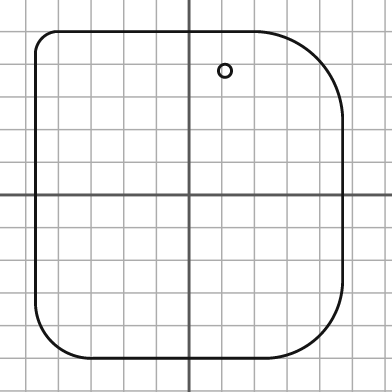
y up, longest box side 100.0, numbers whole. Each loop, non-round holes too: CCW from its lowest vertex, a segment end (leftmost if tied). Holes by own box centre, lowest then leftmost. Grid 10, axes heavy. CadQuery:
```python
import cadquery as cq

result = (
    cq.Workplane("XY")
    .moveTo(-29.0, -50.0)
    .lineTo(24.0, -50.0)
    .threePointArc((40.0, -43.0), (47.0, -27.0))
    .lineTo(47.0, 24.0)
    .threePointArc((39.0, 42.0), (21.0, 50.0))
    .lineTo(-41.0, 50.0)
    .threePointArc((-45.0, 48.0), (-47.0, 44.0))
    .lineTo(-47.0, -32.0)
    .threePointArc((-42.0, -45.0), (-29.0, -50.0))
    .close()
    .moveTo(11.0, 38.0)
    .circle(2.0)
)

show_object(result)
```